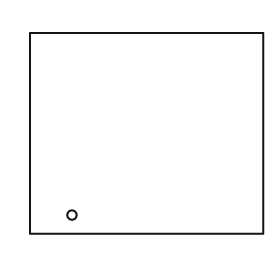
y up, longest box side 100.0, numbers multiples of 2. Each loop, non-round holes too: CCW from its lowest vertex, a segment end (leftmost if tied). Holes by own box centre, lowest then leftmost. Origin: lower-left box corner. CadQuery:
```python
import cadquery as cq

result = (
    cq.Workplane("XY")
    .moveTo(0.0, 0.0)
    .lineTo(100.0, 0.0)
    .lineTo(100.0, 86.0)
    .lineTo(0.0, 86.0)
    .close()
    .moveTo(18.0, 8.0)
    .circle(2.0)
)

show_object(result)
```